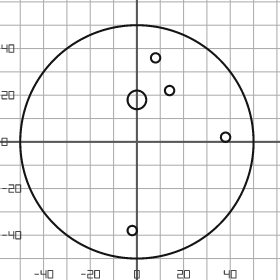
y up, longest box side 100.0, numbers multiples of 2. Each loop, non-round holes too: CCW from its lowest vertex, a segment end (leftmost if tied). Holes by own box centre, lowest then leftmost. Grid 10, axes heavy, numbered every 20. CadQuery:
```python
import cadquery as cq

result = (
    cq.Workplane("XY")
    .moveTo(0.0, 0.0)
    .circle(50.0)
    .moveTo(-2.0, -38.0)
    .circle(2.0)
    .moveTo(38.0, 2.0)
    .circle(2.0)
    .moveTo(0.0, 18.0)
    .circle(4.0)
    .moveTo(14.0, 22.0)
    .circle(2.0)
    .moveTo(8.0, 36.0)
    .circle(2.0)
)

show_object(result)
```